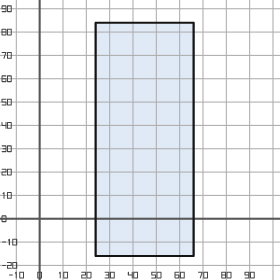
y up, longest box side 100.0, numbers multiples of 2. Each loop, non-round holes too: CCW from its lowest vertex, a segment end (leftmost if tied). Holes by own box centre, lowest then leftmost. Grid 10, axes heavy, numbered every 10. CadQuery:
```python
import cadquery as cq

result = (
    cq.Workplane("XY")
    .moveTo(24.0, -16.0)
    .lineTo(66.0, -16.0)
    .lineTo(66.0, 84.0)
    .lineTo(24.0, 84.0)
    .close()
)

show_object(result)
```